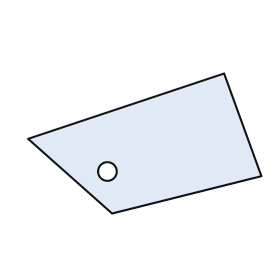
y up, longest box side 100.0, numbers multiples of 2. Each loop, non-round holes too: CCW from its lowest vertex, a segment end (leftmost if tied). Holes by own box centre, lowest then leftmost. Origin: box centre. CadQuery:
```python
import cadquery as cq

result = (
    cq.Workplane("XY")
    .moveTo(-14.0, -30.0)
    .lineTo(50.0, -14.0)
    .lineTo(34.0, 30.0)
    .lineTo(-50.0, 2.0)
    .close()
    .moveTo(-16.0, -12.0)
    .circle(4.0)
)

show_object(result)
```